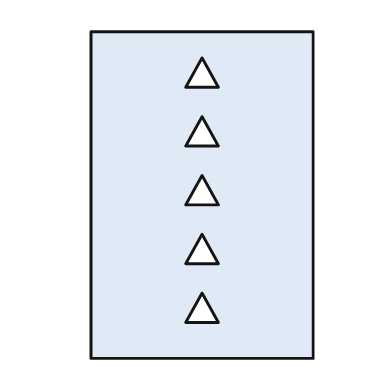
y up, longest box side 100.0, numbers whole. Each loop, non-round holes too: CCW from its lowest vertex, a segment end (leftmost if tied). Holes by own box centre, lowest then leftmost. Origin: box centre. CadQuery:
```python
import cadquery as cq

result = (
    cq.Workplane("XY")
    .moveTo(-34.0, -50.0)
    .lineTo(34.0, -50.0)
    .lineTo(34.0, 50.0)
    .lineTo(-34.0, 50.0)
    .close()
    .moveTo(-5.0, -39.0)
    .lineTo(5.0, -39.0)
    .lineTo(0.0, -30.0)
    .close()
    .moveTo(-5.0, -21.0)
    .lineTo(5.0, -21.0)
    .lineTo(0.0, -12.0)
    .close()
    .moveTo(-5.0, -3.0)
    .lineTo(5.0, -3.0)
    .lineTo(0.0, 6.0)
    .close()
    .moveTo(-5.0, 15.0)
    .lineTo(5.0, 15.0)
    .lineTo(0.0, 24.0)
    .close()
    .moveTo(-5.0, 33.0)
    .lineTo(5.0, 33.0)
    .lineTo(0.0, 42.0)
    .close()
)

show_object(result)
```